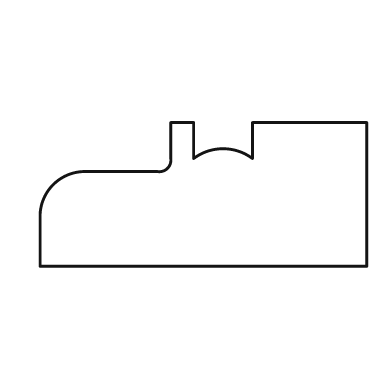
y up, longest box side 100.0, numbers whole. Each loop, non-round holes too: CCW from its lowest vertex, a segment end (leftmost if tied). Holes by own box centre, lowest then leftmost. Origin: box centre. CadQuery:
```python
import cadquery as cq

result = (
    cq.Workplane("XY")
    .moveTo(-50.0, -22.0)
    .lineTo(50.0, -22.0)
    .lineTo(50.0, 22.0)
    .lineTo(15.0, 22.0)
    .lineTo(15.0, 11.0)
    .threePointArc((6.0, 14.0), (-3.0, 11.0))
    .lineTo(-3.0, 22.0)
    .lineTo(-10.0, 22.0)
    .lineTo(-10.0, 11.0)
    .threePointArc((-11.0, 8.0), (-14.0, 7.0))
    .lineTo(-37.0, 7.0)
    .threePointArc((-46.0, 3.0), (-50.0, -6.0))
    .close()
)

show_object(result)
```